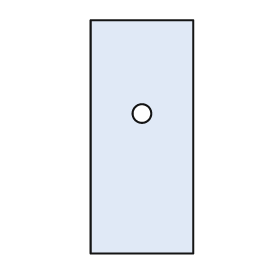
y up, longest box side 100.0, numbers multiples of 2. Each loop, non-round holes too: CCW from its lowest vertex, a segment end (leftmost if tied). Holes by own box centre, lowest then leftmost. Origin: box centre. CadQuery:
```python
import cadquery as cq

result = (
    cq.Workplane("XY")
    .moveTo(-22.0, -50.0)
    .lineTo(22.0, -50.0)
    .lineTo(22.0, 50.0)
    .lineTo(-22.0, 50.0)
    .close()
    .moveTo(0.0, 10.0)
    .circle(4.0)
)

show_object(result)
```